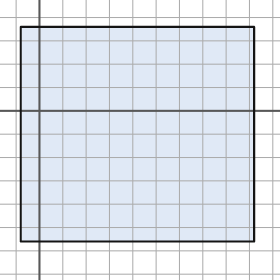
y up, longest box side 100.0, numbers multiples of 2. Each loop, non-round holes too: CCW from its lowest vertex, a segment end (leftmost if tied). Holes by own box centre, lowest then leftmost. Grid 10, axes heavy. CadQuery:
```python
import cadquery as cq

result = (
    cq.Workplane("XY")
    .moveTo(-8.0, -56.0)
    .lineTo(92.0, -56.0)
    .lineTo(92.0, 36.0)
    .lineTo(-8.0, 36.0)
    .close()
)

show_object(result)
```